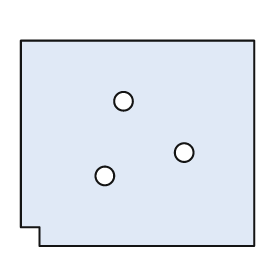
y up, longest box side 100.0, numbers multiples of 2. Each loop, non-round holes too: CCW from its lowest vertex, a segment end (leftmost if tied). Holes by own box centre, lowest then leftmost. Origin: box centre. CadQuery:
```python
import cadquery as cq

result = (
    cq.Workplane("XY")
    .moveTo(-42.0, -44.0)
    .lineTo(50.0, -44.0)
    .lineTo(50.0, 44.0)
    .lineTo(-50.0, 44.0)
    .lineTo(-50.0, -36.0)
    .lineTo(-42.0, -36.0)
    .close()
    .moveTo(-14.0, -14.0)
    .circle(4.0)
    .moveTo(20.0, -4.0)
    .circle(4.0)
    .moveTo(-6.0, 18.0)
    .circle(4.0)
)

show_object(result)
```